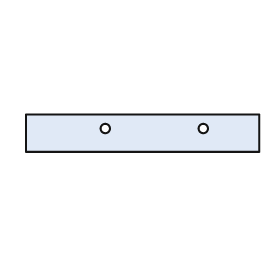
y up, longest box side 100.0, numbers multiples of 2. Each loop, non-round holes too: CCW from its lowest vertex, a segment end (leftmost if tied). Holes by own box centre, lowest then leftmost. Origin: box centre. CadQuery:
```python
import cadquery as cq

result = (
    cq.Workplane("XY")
    .moveTo(-50.0, -8.0)
    .lineTo(50.0, -8.0)
    .lineTo(50.0, 8.0)
    .lineTo(-50.0, 8.0)
    .close()
    .moveTo(-16.0, 2.0)
    .circle(2.0)
    .moveTo(26.0, 2.0)
    .circle(2.0)
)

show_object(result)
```